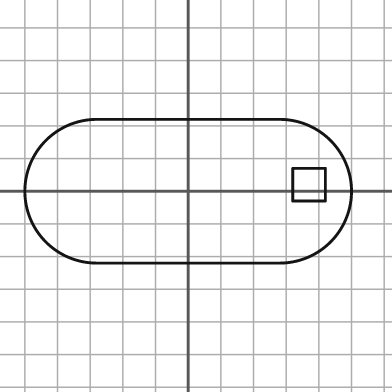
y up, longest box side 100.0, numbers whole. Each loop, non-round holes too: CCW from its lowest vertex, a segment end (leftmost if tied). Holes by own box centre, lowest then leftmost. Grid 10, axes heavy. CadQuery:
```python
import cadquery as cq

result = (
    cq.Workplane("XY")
    .moveTo(-28.0, -22.0)
    .lineTo(28.0, -22.0)
    .threePointArc((50.0, 0.0), (28.0, 22.0))
    .lineTo(-28.0, 22.0)
    .threePointArc((-50.0, 0.0), (-28.0, -22.0))
    .close()
    .moveTo(32.0, -3.0)
    .lineTo(42.0, -3.0)
    .lineTo(42.0, 7.0)
    .lineTo(32.0, 7.0)
    .close()
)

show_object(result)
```